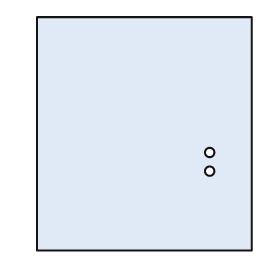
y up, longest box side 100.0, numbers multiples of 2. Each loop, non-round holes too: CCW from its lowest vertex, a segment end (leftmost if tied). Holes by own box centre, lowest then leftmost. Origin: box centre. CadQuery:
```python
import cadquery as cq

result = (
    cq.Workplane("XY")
    .moveTo(-46.0, -50.0)
    .lineTo(46.0, -50.0)
    .lineTo(46.0, 50.0)
    .lineTo(-46.0, 50.0)
    .close()
    .moveTo(28.0, -16.0)
    .circle(2.0)
    .moveTo(28.0, -8.0)
    .circle(2.0)
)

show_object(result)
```